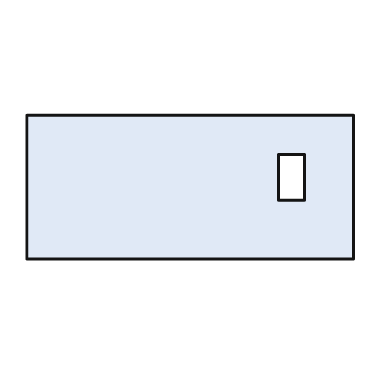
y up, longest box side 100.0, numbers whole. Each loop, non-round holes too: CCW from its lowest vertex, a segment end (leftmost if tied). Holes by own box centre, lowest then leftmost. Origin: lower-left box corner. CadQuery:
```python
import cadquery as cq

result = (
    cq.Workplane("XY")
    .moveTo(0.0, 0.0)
    .lineTo(100.0, 0.0)
    .lineTo(100.0, 44.0)
    .lineTo(0.0, 44.0)
    .close()
    .moveTo(77.0, 18.0)
    .lineTo(85.0, 18.0)
    .lineTo(85.0, 32.0)
    .lineTo(77.0, 32.0)
    .close()
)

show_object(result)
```